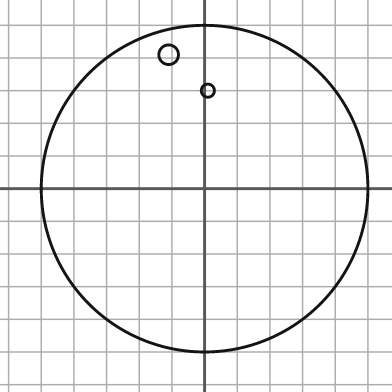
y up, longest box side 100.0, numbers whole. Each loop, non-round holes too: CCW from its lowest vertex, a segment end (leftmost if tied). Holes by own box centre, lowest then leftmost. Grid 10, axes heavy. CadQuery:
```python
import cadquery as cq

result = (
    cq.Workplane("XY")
    .moveTo(0.0, 0.0)
    .circle(50.0)
    .moveTo(1.0, 30.0)
    .circle(2.0)
    .moveTo(-11.0, 41.0)
    .circle(3.0)
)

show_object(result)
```